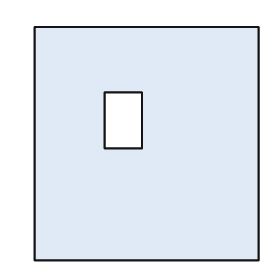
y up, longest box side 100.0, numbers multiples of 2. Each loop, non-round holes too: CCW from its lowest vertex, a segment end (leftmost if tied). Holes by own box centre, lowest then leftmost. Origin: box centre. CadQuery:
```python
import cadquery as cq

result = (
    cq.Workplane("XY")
    .moveTo(-48.0, -50.0)
    .lineTo(48.0, -50.0)
    .lineTo(48.0, 50.0)
    .lineTo(-48.0, 50.0)
    .close()
    .moveTo(-18.0, -2.0)
    .lineTo(-2.0, -2.0)
    .lineTo(-2.0, 22.0)
    .lineTo(-18.0, 22.0)
    .close()
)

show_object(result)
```